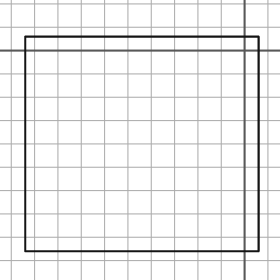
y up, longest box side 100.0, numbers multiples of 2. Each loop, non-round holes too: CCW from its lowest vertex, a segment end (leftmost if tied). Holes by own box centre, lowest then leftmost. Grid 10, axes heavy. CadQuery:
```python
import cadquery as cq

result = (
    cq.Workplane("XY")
    .moveTo(-94.0, -86.0)
    .lineTo(6.0, -86.0)
    .lineTo(6.0, 6.0)
    .lineTo(-94.0, 6.0)
    .close()
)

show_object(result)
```